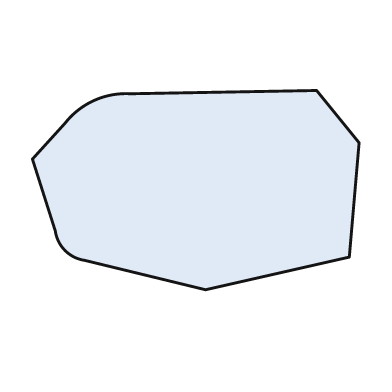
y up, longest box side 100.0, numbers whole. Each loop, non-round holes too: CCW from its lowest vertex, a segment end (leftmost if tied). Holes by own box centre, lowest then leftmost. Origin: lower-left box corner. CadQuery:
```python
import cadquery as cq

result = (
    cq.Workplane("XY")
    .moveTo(53.0, 0.0)
    .lineTo(97.0, 10.0)
    .lineTo(100.0, 45.0)
    .lineTo(87.0, 61.0)
    .lineTo(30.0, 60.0)
    .threePointArc((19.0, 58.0), (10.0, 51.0))
    .lineTo(0.0, 40.0)
    .lineTo(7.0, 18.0)
    .threePointArc((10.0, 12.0), (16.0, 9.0))
    .close()
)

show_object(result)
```